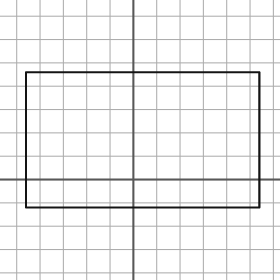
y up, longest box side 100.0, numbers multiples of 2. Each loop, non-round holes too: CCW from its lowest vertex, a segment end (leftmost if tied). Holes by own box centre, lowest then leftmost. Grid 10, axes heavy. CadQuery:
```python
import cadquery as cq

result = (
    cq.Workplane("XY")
    .moveTo(-46.0, -12.0)
    .lineTo(54.0, -12.0)
    .lineTo(54.0, 46.0)
    .lineTo(-46.0, 46.0)
    .close()
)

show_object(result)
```